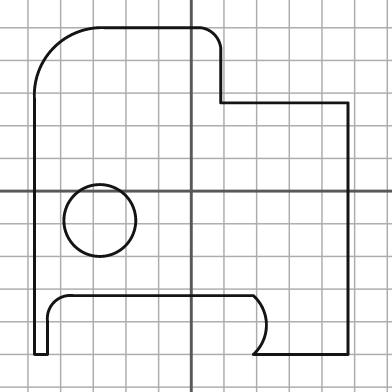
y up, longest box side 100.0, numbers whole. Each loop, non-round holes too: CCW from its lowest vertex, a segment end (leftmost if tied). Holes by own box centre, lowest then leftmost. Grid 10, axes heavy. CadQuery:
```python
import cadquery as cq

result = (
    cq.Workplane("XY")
    .moveTo(-48.0, -50.0)
    .lineTo(-44.0, -50.0)
    .lineTo(-44.0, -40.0)
    .threePointArc((-42.0, -34.0), (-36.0, -32.0))
    .lineTo(19.0, -32.0)
    .threePointArc((23.0, -41.0), (19.0, -50.0))
    .lineTo(48.0, -50.0)
    .lineTo(48.0, 27.0)
    .lineTo(9.0, 27.0)
    .lineTo(9.0, 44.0)
    .threePointArc((7.0, 48.0), (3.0, 50.0))
    .lineTo(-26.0, 50.0)
    .threePointArc((-42.0, 44.0), (-48.0, 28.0))
    .close()
    .moveTo(-28.0, -9.0)
    .circle(11.0)
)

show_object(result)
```